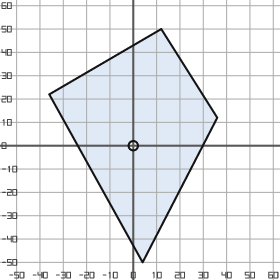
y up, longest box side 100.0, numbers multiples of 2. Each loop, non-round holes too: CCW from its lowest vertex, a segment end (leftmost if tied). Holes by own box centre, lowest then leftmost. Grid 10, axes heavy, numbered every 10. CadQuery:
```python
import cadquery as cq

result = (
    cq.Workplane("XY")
    .moveTo(4.0, -50.0)
    .lineTo(36.0, 12.0)
    .lineTo(12.0, 50.0)
    .lineTo(-36.0, 22.0)
    .close()
    .moveTo(0.0, 0.0)
    .circle(2.0)
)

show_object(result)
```